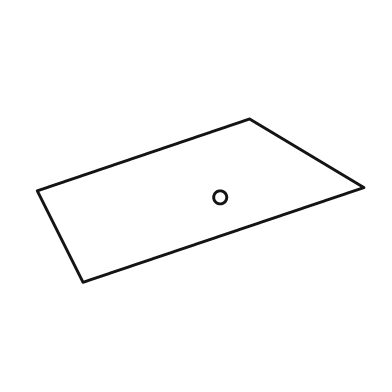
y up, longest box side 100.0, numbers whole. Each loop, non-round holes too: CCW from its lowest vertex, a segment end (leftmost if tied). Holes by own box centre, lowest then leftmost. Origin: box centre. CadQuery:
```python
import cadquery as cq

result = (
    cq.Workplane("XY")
    .moveTo(-36.0, -25.0)
    .lineTo(50.0, 4.0)
    .lineTo(15.0, 25.0)
    .lineTo(-50.0, 3.0)
    .close()
    .moveTo(6.0, 1.0)
    .circle(2.0)
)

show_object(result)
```